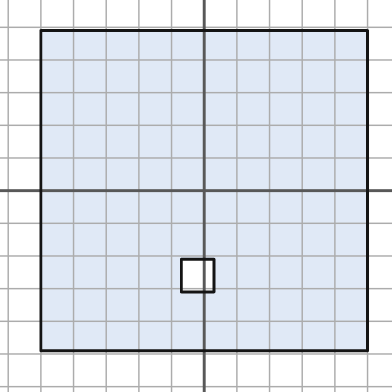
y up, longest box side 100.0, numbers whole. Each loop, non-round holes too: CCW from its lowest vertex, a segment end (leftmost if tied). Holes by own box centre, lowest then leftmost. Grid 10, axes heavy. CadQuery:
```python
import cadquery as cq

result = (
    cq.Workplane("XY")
    .moveTo(-50.0, -49.0)
    .lineTo(50.0, -49.0)
    .lineTo(50.0, 49.0)
    .lineTo(-50.0, 49.0)
    .close()
    .moveTo(-7.0, -31.0)
    .lineTo(3.0, -31.0)
    .lineTo(3.0, -21.0)
    .lineTo(-7.0, -21.0)
    .close()
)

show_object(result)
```